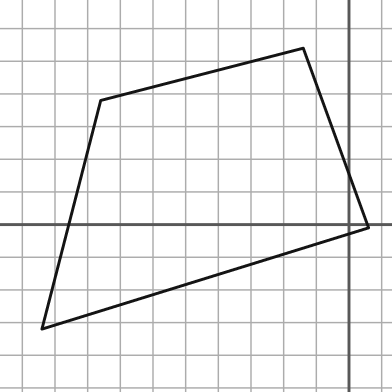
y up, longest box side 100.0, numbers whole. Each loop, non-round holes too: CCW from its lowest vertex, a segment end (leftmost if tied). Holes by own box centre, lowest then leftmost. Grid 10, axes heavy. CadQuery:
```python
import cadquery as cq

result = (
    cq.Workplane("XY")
    .moveTo(-94.0, -32.0)
    .lineTo(6.0, -1.0)
    .lineTo(-14.0, 54.0)
    .lineTo(-76.0, 38.0)
    .close()
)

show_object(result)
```